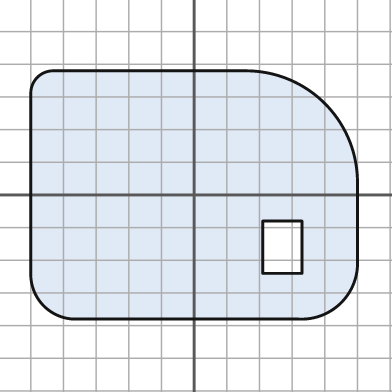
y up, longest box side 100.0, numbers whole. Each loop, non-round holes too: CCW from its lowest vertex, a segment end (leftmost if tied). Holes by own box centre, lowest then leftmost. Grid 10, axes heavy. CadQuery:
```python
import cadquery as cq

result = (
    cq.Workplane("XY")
    .moveTo(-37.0, -38.0)
    .lineTo(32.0, -38.0)
    .threePointArc((45.0, -33.0), (50.0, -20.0))
    .lineTo(50.0, 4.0)
    .threePointArc((40.0, 28.0), (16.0, 38.0))
    .lineTo(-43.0, 38.0)
    .threePointArc((-48.0, 36.0), (-50.0, 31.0))
    .lineTo(-50.0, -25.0)
    .threePointArc((-46.0, -34.0), (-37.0, -38.0))
    .close()
    .moveTo(21.0, -24.0)
    .lineTo(33.0, -24.0)
    .lineTo(33.0, -8.0)
    .lineTo(21.0, -8.0)
    .close()
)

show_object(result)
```